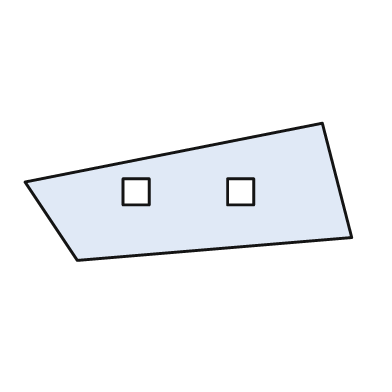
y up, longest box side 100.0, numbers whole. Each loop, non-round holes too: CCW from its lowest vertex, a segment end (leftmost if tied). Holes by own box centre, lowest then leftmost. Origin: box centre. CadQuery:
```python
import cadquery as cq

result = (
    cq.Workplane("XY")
    .moveTo(-34.0, -21.0)
    .lineTo(50.0, -14.0)
    .lineTo(41.0, 21.0)
    .lineTo(-50.0, 3.0)
    .close()
    .moveTo(-20.0, -4.0)
    .lineTo(-12.0, -4.0)
    .lineTo(-12.0, 4.0)
    .lineTo(-20.0, 4.0)
    .close()
    .moveTo(12.0, -4.0)
    .lineTo(20.0, -4.0)
    .lineTo(20.0, 4.0)
    .lineTo(12.0, 4.0)
    .close()
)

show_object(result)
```